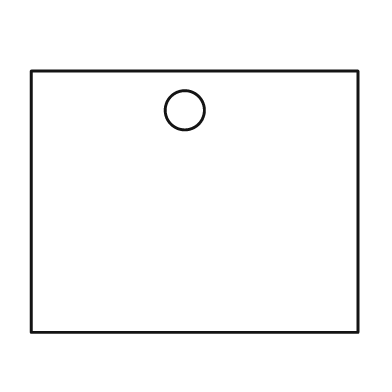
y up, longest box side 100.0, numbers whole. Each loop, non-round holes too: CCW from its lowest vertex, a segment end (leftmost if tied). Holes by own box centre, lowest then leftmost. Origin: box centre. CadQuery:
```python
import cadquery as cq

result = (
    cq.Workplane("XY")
    .moveTo(-50.0, -40.0)
    .lineTo(50.0, -40.0)
    .lineTo(50.0, 40.0)
    .lineTo(-50.0, 40.0)
    .close()
    .moveTo(-3.0, 28.0)
    .circle(6.0)
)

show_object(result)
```